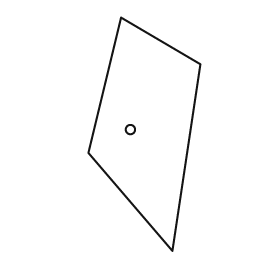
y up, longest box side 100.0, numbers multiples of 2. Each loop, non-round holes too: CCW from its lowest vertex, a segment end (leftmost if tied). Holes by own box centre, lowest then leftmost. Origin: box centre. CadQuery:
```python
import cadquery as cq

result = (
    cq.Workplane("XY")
    .moveTo(12.0, -50.0)
    .lineTo(24.0, 30.0)
    .lineTo(-10.0, 50.0)
    .lineTo(-24.0, -8.0)
    .close()
    .moveTo(-6.0, 2.0)
    .circle(2.0)
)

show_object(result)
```